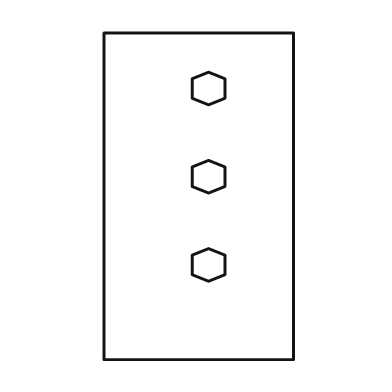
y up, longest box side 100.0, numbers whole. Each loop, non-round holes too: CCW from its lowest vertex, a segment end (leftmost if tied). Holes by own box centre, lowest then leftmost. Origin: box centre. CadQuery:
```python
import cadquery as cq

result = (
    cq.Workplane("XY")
    .moveTo(-29.0, -50.0)
    .lineTo(29.0, -50.0)
    .lineTo(29.0, 50.0)
    .lineTo(-29.0, 50.0)
    .close()
    .moveTo(3.0, -26.0)
    .lineTo(8.0, -24.0)
    .lineTo(8.0, -18.0)
    .lineTo(3.0, -16.0)
    .lineTo(-2.0, -18.0)
    .lineTo(-2.0, -24.0)
    .close()
    .moveTo(3.0, 1.0)
    .lineTo(8.0, 3.0)
    .lineTo(8.0, 9.0)
    .lineTo(3.0, 11.0)
    .lineTo(-2.0, 9.0)
    .lineTo(-2.0, 3.0)
    .close()
    .moveTo(3.0, 28.0)
    .lineTo(8.0, 30.0)
    .lineTo(8.0, 36.0)
    .lineTo(3.0, 38.0)
    .lineTo(-2.0, 36.0)
    .lineTo(-2.0, 30.0)
    .close()
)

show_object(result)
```